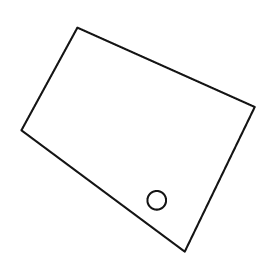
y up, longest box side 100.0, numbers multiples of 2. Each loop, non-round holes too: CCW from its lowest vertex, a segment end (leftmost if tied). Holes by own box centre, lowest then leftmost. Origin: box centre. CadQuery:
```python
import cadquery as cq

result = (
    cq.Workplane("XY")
    .moveTo(20.0, -48.0)
    .lineTo(50.0, 14.0)
    .lineTo(-26.0, 48.0)
    .lineTo(-50.0, 4.0)
    .close()
    .moveTo(8.0, -26.0)
    .circle(4.0)
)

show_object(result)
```